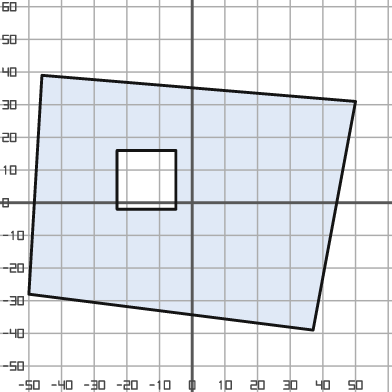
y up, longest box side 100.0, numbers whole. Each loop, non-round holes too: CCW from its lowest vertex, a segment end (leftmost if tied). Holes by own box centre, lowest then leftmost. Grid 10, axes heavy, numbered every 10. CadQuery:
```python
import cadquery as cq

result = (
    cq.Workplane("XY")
    .moveTo(37.0, -39.0)
    .lineTo(50.0, 31.0)
    .lineTo(-46.0, 39.0)
    .lineTo(-50.0, -28.0)
    .close()
    .moveTo(-23.0, -2.0)
    .lineTo(-5.0, -2.0)
    .lineTo(-5.0, 16.0)
    .lineTo(-23.0, 16.0)
    .close()
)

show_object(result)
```